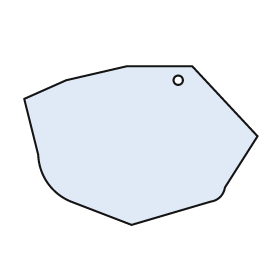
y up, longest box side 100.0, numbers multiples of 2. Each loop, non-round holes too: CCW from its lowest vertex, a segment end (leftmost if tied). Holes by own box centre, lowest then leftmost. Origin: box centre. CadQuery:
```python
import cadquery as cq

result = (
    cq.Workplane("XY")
    .moveTo(-4.0, -34.0)
    .lineTo(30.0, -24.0)
    .threePointArc((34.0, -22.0), (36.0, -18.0))
    .lineTo(50.0, 4.0)
    .lineTo(22.0, 34.0)
    .lineTo(-6.0, 34.0)
    .lineTo(-32.0, 28.0)
    .lineTo(-50.0, 20.0)
    .lineTo(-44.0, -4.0)
    .threePointArc((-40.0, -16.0), (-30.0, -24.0))
    .close()
    .moveTo(16.0, 28.0)
    .circle(2.0)
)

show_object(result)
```